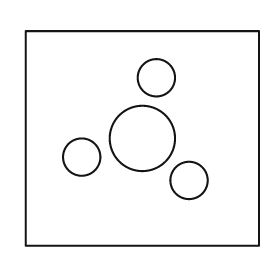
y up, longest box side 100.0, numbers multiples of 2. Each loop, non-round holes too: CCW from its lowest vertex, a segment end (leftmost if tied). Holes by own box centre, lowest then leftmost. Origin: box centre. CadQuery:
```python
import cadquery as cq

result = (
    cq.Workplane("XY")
    .moveTo(-50.0, -46.0)
    .lineTo(50.0, -46.0)
    .lineTo(50.0, 46.0)
    .lineTo(-50.0, 46.0)
    .close()
    .moveTo(20.0, -18.0)
    .circle(8.0)
    .moveTo(-26.0, -8.0)
    .circle(8.0)
    .moveTo(0.0, 0.0)
    .circle(14.0)
    .moveTo(6.0, 26.0)
    .circle(8.0)
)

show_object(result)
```